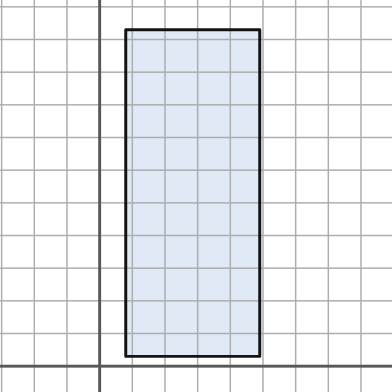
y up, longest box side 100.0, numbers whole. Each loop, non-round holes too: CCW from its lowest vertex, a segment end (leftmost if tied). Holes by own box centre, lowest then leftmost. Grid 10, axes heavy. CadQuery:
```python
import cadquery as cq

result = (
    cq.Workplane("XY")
    .moveTo(8.0, 3.0)
    .lineTo(49.0, 3.0)
    .lineTo(49.0, 103.0)
    .lineTo(8.0, 103.0)
    .close()
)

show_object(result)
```